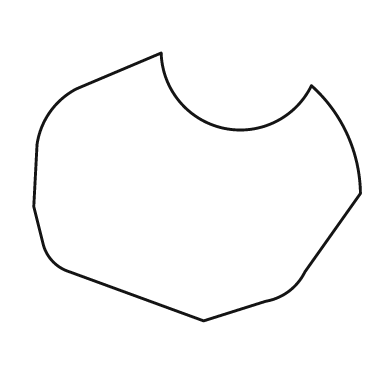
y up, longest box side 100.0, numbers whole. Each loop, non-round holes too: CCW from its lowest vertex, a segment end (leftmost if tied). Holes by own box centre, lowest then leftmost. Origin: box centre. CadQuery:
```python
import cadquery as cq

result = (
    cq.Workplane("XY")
    .moveTo(2.0, -41.0)
    .lineTo(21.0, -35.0)
    .threePointArc((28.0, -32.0), (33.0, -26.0))
    .lineTo(50.0, -2.0)
    .threePointArc((46.0, 16.0), (35.0, 31.0))
    .threePointArc((8.0, 18.0), (-11.0, 41.0))
    .lineTo(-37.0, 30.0)
    .threePointArc((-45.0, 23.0), (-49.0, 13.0))
    .lineTo(-50.0, -6.0)
    .lineTo(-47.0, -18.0)
    .threePointArc((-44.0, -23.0), (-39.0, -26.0))
    .close()
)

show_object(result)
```